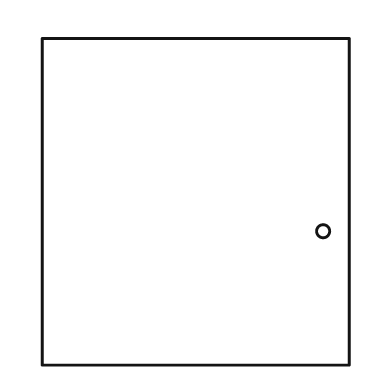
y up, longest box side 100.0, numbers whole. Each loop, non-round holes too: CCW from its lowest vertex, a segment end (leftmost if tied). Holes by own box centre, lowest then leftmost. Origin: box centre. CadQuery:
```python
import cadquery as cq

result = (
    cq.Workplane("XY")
    .moveTo(-47.0, -50.0)
    .lineTo(47.0, -50.0)
    .lineTo(47.0, 50.0)
    .lineTo(-47.0, 50.0)
    .close()
    .moveTo(39.0, -9.0)
    .circle(2.0)
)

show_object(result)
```